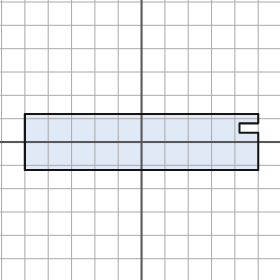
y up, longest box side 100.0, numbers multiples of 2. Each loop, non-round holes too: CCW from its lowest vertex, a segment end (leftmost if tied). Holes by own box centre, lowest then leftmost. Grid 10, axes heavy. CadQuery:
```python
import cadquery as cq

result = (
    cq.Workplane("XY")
    .moveTo(-50.0, -12.0)
    .lineTo(50.0, -12.0)
    .lineTo(50.0, 4.0)
    .lineTo(42.0, 4.0)
    .lineTo(42.0, 8.0)
    .lineTo(50.0, 8.0)
    .lineTo(50.0, 12.0)
    .lineTo(-50.0, 12.0)
    .close()
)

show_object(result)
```